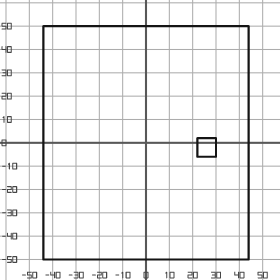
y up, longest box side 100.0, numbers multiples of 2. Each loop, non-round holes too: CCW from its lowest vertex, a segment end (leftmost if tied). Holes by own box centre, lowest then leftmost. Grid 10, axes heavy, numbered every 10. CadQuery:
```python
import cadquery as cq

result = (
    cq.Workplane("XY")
    .moveTo(-44.0, -50.0)
    .lineTo(44.0, -50.0)
    .lineTo(44.0, 50.0)
    .lineTo(-44.0, 50.0)
    .close()
    .moveTo(22.0, -6.0)
    .lineTo(30.0, -6.0)
    .lineTo(30.0, 2.0)
    .lineTo(22.0, 2.0)
    .close()
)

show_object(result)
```